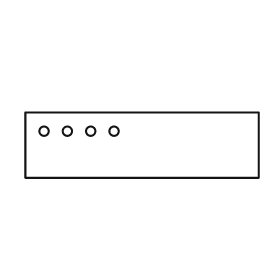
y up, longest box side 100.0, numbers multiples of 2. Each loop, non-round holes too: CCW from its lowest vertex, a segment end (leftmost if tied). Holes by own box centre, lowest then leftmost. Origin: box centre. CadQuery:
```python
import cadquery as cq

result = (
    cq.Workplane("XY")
    .moveTo(-50.0, -14.0)
    .lineTo(50.0, -14.0)
    .lineTo(50.0, 14.0)
    .lineTo(-50.0, 14.0)
    .close()
    .moveTo(-42.0, 6.0)
    .circle(2.0)
    .moveTo(-32.0, 6.0)
    .circle(2.0)
    .moveTo(-22.0, 6.0)
    .circle(2.0)
    .moveTo(-12.0, 6.0)
    .circle(2.0)
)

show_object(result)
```